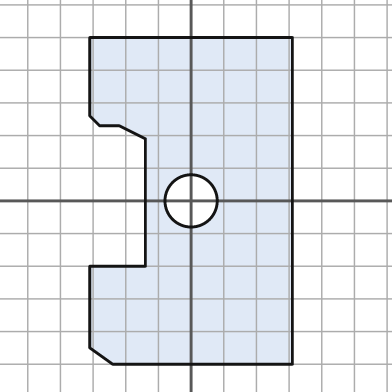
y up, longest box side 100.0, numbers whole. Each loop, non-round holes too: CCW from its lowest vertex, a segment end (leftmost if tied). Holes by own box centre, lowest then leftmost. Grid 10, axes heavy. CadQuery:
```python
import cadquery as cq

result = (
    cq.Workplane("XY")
    .moveTo(-24.0, -50.0)
    .lineTo(31.0, -50.0)
    .lineTo(31.0, 50.0)
    .lineTo(-31.0, 50.0)
    .lineTo(-31.0, 26.0)
    .lineTo(-28.0, 23.0)
    .lineTo(-22.0, 23.0)
    .lineTo(-14.0, 19.0)
    .lineTo(-14.0, -20.0)
    .lineTo(-31.0, -20.0)
    .lineTo(-31.0, -45.0)
    .close()
    .moveTo(0.0, 0.0)
    .circle(8.0)
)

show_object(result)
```